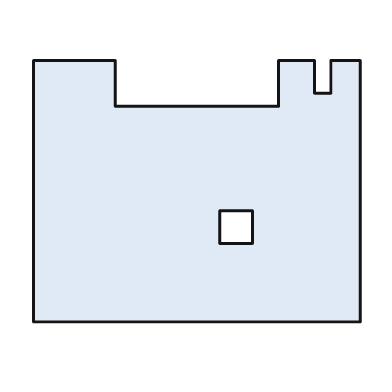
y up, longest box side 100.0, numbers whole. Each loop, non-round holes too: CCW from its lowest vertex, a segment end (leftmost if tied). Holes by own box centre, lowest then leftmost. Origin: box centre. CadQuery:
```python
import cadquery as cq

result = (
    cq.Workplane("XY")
    .moveTo(-50.0, -40.0)
    .lineTo(50.0, -40.0)
    .lineTo(50.0, 40.0)
    .lineTo(41.0, 40.0)
    .lineTo(41.0, 30.0)
    .lineTo(36.0, 30.0)
    .lineTo(36.0, 40.0)
    .lineTo(25.0, 40.0)
    .lineTo(25.0, 26.0)
    .lineTo(-25.0, 26.0)
    .lineTo(-25.0, 40.0)
    .lineTo(-50.0, 40.0)
    .close()
    .moveTo(7.0, -16.0)
    .lineTo(17.0, -16.0)
    .lineTo(17.0, -6.0)
    .lineTo(7.0, -6.0)
    .close()
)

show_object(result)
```